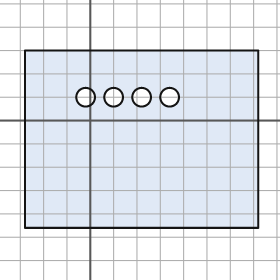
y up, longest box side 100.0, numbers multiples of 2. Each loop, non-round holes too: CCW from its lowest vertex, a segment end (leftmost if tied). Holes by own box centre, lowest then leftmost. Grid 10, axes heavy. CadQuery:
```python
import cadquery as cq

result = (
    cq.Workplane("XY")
    .moveTo(-28.0, -46.0)
    .lineTo(72.0, -46.0)
    .lineTo(72.0, 30.0)
    .lineTo(-28.0, 30.0)
    .close()
    .moveTo(-2.0, 10.0)
    .circle(4.0)
    .moveTo(10.0, 10.0)
    .circle(4.0)
    .moveTo(22.0, 10.0)
    .circle(4.0)
    .moveTo(34.0, 10.0)
    .circle(4.0)
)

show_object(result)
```